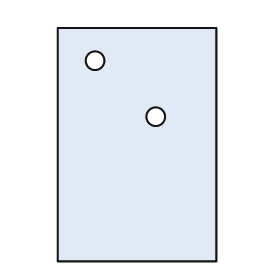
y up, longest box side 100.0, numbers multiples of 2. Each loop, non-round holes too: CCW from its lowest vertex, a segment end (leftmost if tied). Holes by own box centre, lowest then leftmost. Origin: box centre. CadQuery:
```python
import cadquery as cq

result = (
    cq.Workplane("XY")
    .moveTo(-34.0, -50.0)
    .lineTo(34.0, -50.0)
    .lineTo(34.0, 50.0)
    .lineTo(-34.0, 50.0)
    .close()
    .moveTo(8.0, 12.0)
    .circle(4.0)
    .moveTo(-18.0, 36.0)
    .circle(4.0)
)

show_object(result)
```